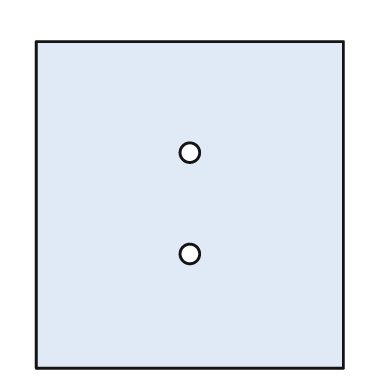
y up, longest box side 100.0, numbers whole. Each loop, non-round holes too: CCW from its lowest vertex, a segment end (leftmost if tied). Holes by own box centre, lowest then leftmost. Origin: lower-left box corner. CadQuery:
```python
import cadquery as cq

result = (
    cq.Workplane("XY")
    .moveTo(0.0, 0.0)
    .lineTo(94.0, 0.0)
    .lineTo(94.0, 100.0)
    .lineTo(0.0, 100.0)
    .close()
    .moveTo(47.0, 35.0)
    .circle(3.0)
    .moveTo(47.0, 66.0)
    .circle(3.0)
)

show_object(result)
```